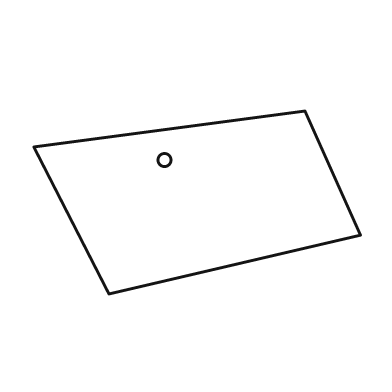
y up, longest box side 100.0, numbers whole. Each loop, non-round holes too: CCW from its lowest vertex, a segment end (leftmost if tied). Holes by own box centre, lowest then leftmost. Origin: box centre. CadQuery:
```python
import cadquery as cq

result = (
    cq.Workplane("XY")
    .moveTo(-27.0, -28.0)
    .lineTo(50.0, -10.0)
    .lineTo(33.0, 28.0)
    .lineTo(-50.0, 17.0)
    .close()
    .moveTo(-10.0, 13.0)
    .circle(2.0)
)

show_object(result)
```